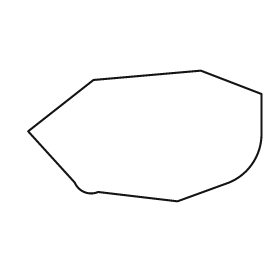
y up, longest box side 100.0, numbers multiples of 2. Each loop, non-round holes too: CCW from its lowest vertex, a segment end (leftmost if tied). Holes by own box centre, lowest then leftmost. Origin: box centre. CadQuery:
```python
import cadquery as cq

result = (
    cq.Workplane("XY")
    .moveTo(14.0, -28.0)
    .lineTo(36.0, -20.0)
    .threePointArc((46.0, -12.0), (50.0, 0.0))
    .lineTo(50.0, 18.0)
    .lineTo(24.0, 28.0)
    .lineTo(-22.0, 24.0)
    .lineTo(-50.0, 2.0)
    .lineTo(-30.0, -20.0)
    .threePointArc((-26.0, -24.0), (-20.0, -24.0))
    .close()
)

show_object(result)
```